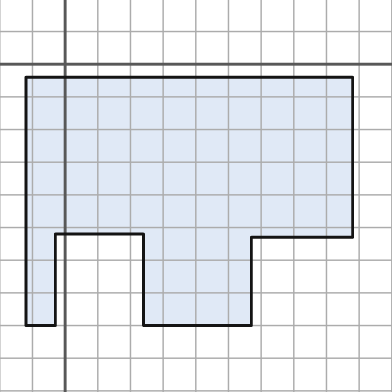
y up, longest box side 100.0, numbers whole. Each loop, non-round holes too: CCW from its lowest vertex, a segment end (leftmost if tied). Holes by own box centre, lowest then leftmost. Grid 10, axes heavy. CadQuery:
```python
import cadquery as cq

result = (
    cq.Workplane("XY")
    .moveTo(-12.0, -80.0)
    .lineTo(-3.0, -80.0)
    .lineTo(-3.0, -52.0)
    .lineTo(24.0, -52.0)
    .lineTo(24.0, -80.0)
    .lineTo(57.0, -80.0)
    .lineTo(57.0, -53.0)
    .lineTo(88.0, -53.0)
    .lineTo(88.0, -4.0)
    .lineTo(-12.0, -4.0)
    .close()
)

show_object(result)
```